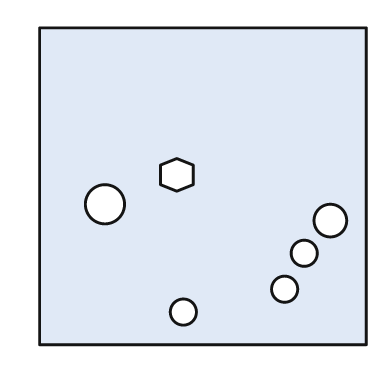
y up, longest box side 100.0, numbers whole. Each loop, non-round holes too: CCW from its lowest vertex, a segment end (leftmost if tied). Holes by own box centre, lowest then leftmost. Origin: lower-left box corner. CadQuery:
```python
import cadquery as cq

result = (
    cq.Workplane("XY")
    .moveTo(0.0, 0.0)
    .lineTo(100.0, 0.0)
    .lineTo(100.0, 97.0)
    .lineTo(0.0, 97.0)
    .close()
    .moveTo(44.0, 10.0)
    .circle(4.0)
    .moveTo(75.0, 17.0)
    .circle(4.0)
    .moveTo(81.0, 28.0)
    .circle(4.0)
    .moveTo(89.0, 38.0)
    .circle(5.0)
    .moveTo(20.0, 43.0)
    .circle(6.0)
    .moveTo(42.0, 47.0)
    .lineTo(47.0, 49.0)
    .lineTo(47.0, 55.0)
    .lineTo(42.0, 57.0)
    .lineTo(37.0, 55.0)
    .lineTo(37.0, 49.0)
    .close()
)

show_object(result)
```